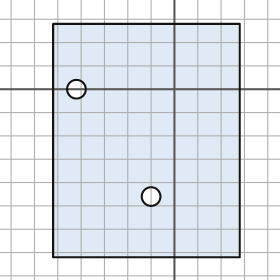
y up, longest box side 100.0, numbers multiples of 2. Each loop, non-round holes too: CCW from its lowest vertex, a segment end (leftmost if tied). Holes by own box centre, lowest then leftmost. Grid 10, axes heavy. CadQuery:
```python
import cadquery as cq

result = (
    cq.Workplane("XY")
    .moveTo(-52.0, -72.0)
    .lineTo(28.0, -72.0)
    .lineTo(28.0, 28.0)
    .lineTo(-52.0, 28.0)
    .close()
    .moveTo(-10.0, -46.0)
    .circle(4.0)
    .moveTo(-42.0, 0.0)
    .circle(4.0)
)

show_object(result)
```